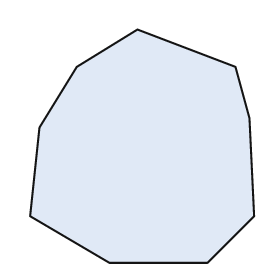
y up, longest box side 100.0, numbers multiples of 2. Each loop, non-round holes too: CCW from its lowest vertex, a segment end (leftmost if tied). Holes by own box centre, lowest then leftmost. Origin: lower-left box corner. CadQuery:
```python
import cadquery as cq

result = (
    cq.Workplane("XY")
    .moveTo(34.0, 0.0)
    .lineTo(76.0, 0.0)
    .lineTo(96.0, 20.0)
    .lineTo(94.0, 62.0)
    .lineTo(88.0, 84.0)
    .lineTo(46.0, 100.0)
    .lineTo(20.0, 84.0)
    .lineTo(4.0, 58.0)
    .lineTo(0.0, 20.0)
    .close()
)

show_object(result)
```